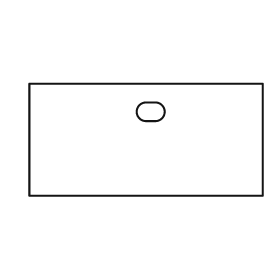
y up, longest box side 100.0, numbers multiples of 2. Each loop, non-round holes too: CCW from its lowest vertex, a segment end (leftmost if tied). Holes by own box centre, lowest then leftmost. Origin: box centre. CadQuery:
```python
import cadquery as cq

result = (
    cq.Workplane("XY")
    .moveTo(-50.0, -24.0)
    .lineTo(50.0, -24.0)
    .lineTo(50.0, 24.0)
    .lineTo(-50.0, 24.0)
    .close()
    .moveTo(0.0, 8.0)
    .lineTo(4.0, 8.0)
    .threePointArc((8.0, 12.0), (4.0, 16.0))
    .lineTo(0.0, 16.0)
    .threePointArc((-4.0, 12.0), (0.0, 8.0))
    .close()
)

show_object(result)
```